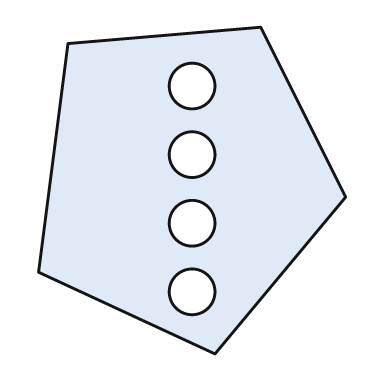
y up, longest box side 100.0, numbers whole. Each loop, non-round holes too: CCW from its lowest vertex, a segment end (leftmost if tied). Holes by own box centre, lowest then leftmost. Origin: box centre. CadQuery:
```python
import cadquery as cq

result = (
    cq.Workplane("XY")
    .moveTo(7.0, -50.0)
    .lineTo(47.0, -2.0)
    .lineTo(21.0, 50.0)
    .lineTo(-38.0, 45.0)
    .lineTo(-47.0, -25.0)
    .close()
    .moveTo(0.0, -31.0)
    .circle(7.0)
    .moveTo(0.0, -10.0)
    .circle(7.0)
    .moveTo(0.0, 11.0)
    .circle(7.0)
    .moveTo(0.0, 32.0)
    .circle(7.0)
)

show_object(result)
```